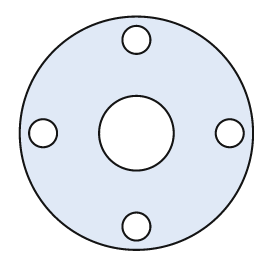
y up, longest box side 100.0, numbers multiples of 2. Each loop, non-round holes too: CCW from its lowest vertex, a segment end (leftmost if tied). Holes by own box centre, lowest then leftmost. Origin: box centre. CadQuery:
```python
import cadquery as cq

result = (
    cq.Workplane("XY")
    .moveTo(0.0, 0.0)
    .circle(50.0)
    .moveTo(0.0, -40.0)
    .circle(6.0)
    .moveTo(-40.0, 0.0)
    .circle(6.0)
    .moveTo(0.0, 0.0)
    .circle(16.0)
    .moveTo(40.0, 0.0)
    .circle(6.0)
    .moveTo(0.0, 40.0)
    .circle(6.0)
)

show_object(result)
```